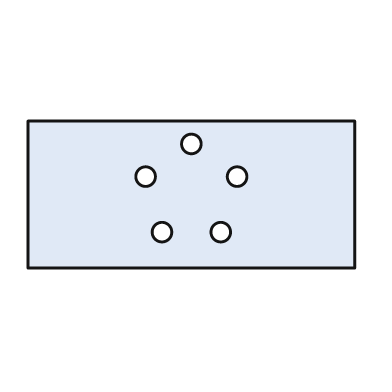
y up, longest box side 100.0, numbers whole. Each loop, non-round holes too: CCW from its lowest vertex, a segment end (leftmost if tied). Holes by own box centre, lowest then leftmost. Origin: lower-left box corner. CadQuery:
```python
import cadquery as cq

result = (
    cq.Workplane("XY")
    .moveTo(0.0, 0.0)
    .lineTo(100.0, 0.0)
    .lineTo(100.0, 45.0)
    .lineTo(0.0, 45.0)
    .close()
    .moveTo(41.0, 11.0)
    .circle(3.0)
    .moveTo(59.0, 11.0)
    .circle(3.0)
    .moveTo(36.0, 28.0)
    .circle(3.0)
    .moveTo(64.0, 28.0)
    .circle(3.0)
    .moveTo(50.0, 38.0)
    .circle(3.0)
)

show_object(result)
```